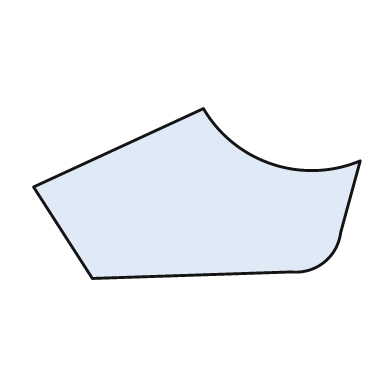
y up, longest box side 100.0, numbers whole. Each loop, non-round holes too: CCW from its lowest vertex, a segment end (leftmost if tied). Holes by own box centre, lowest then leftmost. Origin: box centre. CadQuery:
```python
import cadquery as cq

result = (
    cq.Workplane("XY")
    .moveTo(-32.0, -26.0)
    .lineTo(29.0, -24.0)
    .threePointArc((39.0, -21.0), (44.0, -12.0))
    .lineTo(50.0, 10.0)
    .threePointArc((23.0, 9.0), (2.0, 26.0))
    .lineTo(-50.0, 2.0)
    .close()
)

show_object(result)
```